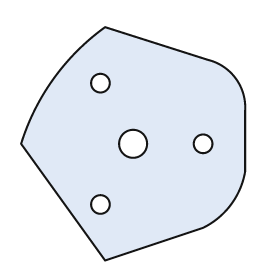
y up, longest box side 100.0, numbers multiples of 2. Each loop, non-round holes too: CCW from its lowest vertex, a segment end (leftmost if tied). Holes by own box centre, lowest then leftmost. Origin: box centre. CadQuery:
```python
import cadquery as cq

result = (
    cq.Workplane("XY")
    .moveTo(-12.0, -50.0)
    .lineTo(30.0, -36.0)
    .threePointArc((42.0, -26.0), (48.0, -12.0))
    .lineTo(48.0, 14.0)
    .threePointArc((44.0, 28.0), (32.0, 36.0))
    .lineTo(-12.0, 50.0)
    .threePointArc((-34.0, 28.0), (-48.0, 0.0))
    .close()
    .moveTo(-14.0, -26.0)
    .circle(4.0)
    .moveTo(0.0, 0.0)
    .circle(6.0)
    .moveTo(30.0, 0.0)
    .circle(4.0)
    .moveTo(-14.0, 26.0)
    .circle(4.0)
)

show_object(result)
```